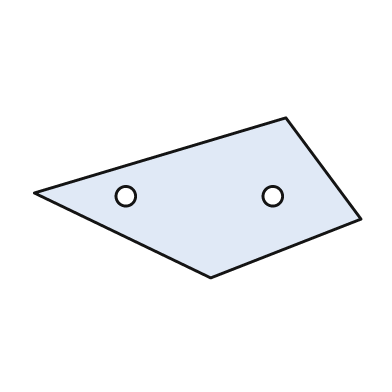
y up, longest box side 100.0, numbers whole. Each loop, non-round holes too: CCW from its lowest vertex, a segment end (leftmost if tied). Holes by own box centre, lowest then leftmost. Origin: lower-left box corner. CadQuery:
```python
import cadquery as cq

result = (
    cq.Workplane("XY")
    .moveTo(54.0, 0.0)
    .lineTo(100.0, 18.0)
    .lineTo(77.0, 49.0)
    .lineTo(0.0, 26.0)
    .close()
    .moveTo(28.0, 25.0)
    .circle(3.0)
    .moveTo(73.0, 25.0)
    .circle(3.0)
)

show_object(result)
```